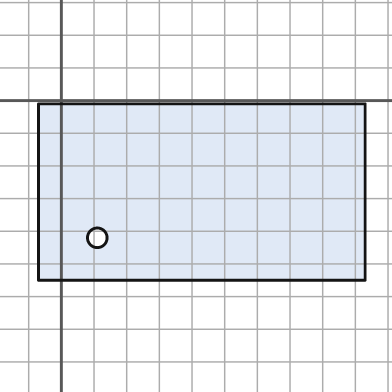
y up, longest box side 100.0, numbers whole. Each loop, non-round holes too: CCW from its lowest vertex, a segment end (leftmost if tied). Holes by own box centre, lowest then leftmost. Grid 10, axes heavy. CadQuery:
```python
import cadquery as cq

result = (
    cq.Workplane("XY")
    .moveTo(-7.0, -55.0)
    .lineTo(93.0, -55.0)
    .lineTo(93.0, -1.0)
    .lineTo(-7.0, -1.0)
    .close()
    .moveTo(11.0, -42.0)
    .circle(3.0)
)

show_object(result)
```